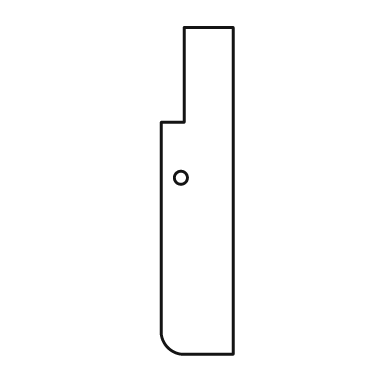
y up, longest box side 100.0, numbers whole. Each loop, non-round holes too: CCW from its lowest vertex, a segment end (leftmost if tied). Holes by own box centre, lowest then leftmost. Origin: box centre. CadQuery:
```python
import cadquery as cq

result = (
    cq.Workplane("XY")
    .moveTo(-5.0, -50.0)
    .lineTo(11.0, -50.0)
    .lineTo(11.0, 50.0)
    .lineTo(-4.0, 50.0)
    .lineTo(-4.0, 21.0)
    .lineTo(-11.0, 21.0)
    .lineTo(-11.0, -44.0)
    .threePointArc((-9.0, -48.0), (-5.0, -50.0))
    .close()
    .moveTo(-5.0, 4.0)
    .circle(2.0)
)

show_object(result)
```